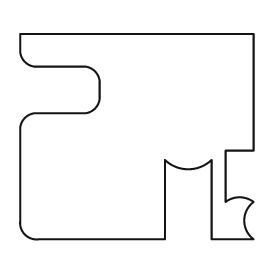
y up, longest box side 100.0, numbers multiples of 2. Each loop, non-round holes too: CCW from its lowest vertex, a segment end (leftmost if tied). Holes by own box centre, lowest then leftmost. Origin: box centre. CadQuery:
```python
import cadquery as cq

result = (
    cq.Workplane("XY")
    .moveTo(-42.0, -44.0)
    .lineTo(12.0, -44.0)
    .lineTo(12.0, -10.0)
    .threePointArc((22.0, -14.0), (32.0, -10.0))
    .lineTo(32.0, -44.0)
    .lineTo(50.0, -44.0)
    .threePointArc((46.0, -36.0), (50.0, -28.0))
    .threePointArc((44.0, -26.0), (38.0, -28.0))
    .lineTo(38.0, -6.0)
    .lineTo(50.0, -6.0)
    .lineTo(50.0, 44.0)
    .lineTo(-50.0, 44.0)
    .lineTo(-50.0, 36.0)
    .threePointArc((-48.0, 32.0), (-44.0, 30.0))
    .lineTo(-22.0, 30.0)
    .threePointArc((-18.0, 28.0), (-16.0, 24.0))
    .lineTo(-16.0, 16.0)
    .threePointArc((-18.0, 12.0), (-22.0, 10.0))
    .lineTo(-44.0, 10.0)
    .threePointArc((-48.0, 8.0), (-50.0, 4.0))
    .lineTo(-50.0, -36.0)
    .threePointArc((-48.0, -42.0), (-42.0, -44.0))
    .close()
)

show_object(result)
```